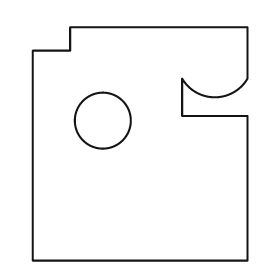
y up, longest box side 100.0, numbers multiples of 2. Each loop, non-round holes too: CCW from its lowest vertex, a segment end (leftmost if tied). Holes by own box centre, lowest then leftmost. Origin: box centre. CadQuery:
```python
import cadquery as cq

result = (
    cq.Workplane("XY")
    .moveTo(-46.0, -50.0)
    .lineTo(46.0, -50.0)
    .lineTo(46.0, 12.0)
    .lineTo(18.0, 12.0)
    .lineTo(18.0, 28.0)
    .threePointArc((32.0, 20.0), (46.0, 28.0))
    .lineTo(46.0, 50.0)
    .lineTo(-30.0, 50.0)
    .lineTo(-30.0, 40.0)
    .lineTo(-46.0, 40.0)
    .close()
    .moveTo(-16.0, 10.0)
    .circle(12.0)
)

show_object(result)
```